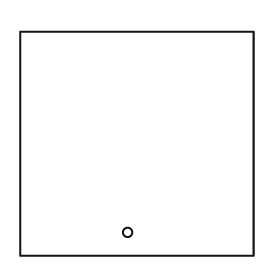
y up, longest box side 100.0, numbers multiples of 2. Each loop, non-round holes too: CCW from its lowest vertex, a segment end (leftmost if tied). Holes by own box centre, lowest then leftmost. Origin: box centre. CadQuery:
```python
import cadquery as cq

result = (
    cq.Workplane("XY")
    .moveTo(-50.0, -48.0)
    .lineTo(50.0, -48.0)
    .lineTo(50.0, 48.0)
    .lineTo(-50.0, 48.0)
    .close()
    .moveTo(-4.0, -38.0)
    .circle(2.0)
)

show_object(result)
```